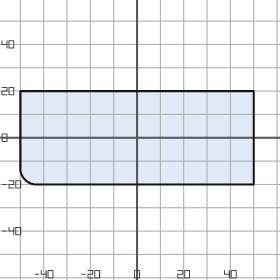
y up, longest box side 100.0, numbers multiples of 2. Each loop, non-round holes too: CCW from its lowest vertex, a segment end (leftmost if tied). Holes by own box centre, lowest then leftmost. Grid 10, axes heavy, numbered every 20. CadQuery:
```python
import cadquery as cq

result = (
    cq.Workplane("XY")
    .moveTo(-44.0, -20.0)
    .lineTo(50.0, -20.0)
    .lineTo(50.0, 20.0)
    .lineTo(-50.0, 20.0)
    .lineTo(-50.0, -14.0)
    .threePointArc((-48.0, -18.0), (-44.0, -20.0))
    .close()
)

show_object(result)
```